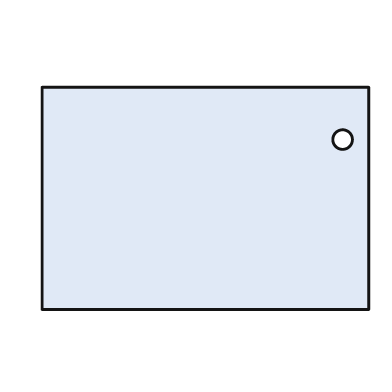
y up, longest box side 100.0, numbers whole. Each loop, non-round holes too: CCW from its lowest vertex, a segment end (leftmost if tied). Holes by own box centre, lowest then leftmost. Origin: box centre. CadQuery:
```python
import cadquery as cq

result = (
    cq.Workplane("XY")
    .moveTo(-50.0, -34.0)
    .lineTo(50.0, -34.0)
    .lineTo(50.0, 34.0)
    .lineTo(-50.0, 34.0)
    .close()
    .moveTo(42.0, 18.0)
    .circle(3.0)
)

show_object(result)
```